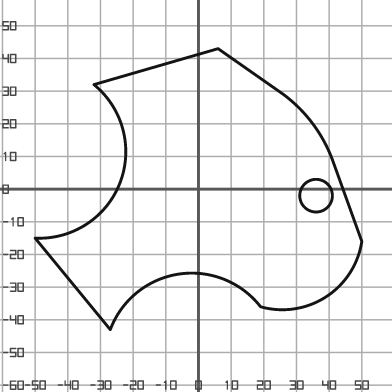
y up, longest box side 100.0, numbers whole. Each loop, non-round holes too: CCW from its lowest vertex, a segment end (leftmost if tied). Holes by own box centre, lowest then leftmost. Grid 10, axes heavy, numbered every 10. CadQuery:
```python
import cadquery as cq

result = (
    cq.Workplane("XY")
    .moveTo(-27.0, -43.0)
    .threePointArc((-6.0, -26.0), (19.0, -36.0))
    .threePointArc((39.0, -33.0), (50.0, -16.0))
    .lineTo(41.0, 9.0)
    .threePointArc((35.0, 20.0), (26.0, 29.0))
    .lineTo(6.0, 43.0)
    .lineTo(-32.0, 32.0)
    .threePointArc((-24.0, 2.0), (-50.0, -15.0))
    .close()
    .moveTo(36.0, -2.0)
    .circle(5.0)
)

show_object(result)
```